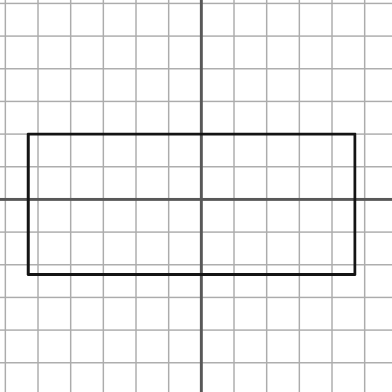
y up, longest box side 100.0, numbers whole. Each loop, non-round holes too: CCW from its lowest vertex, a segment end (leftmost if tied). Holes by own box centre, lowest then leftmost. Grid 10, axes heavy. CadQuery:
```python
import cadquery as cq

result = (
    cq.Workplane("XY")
    .moveTo(-53.0, -23.0)
    .lineTo(47.0, -23.0)
    .lineTo(47.0, 20.0)
    .lineTo(-53.0, 20.0)
    .close()
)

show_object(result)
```